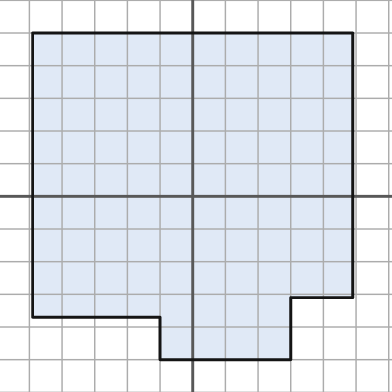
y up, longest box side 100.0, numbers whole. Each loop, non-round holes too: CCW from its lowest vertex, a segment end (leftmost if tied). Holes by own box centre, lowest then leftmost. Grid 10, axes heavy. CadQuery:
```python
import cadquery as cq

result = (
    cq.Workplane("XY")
    .moveTo(-10.0, -50.0)
    .lineTo(30.0, -50.0)
    .lineTo(30.0, -31.0)
    .lineTo(49.0, -31.0)
    .lineTo(49.0, 50.0)
    .lineTo(-49.0, 50.0)
    .lineTo(-49.0, -37.0)
    .lineTo(-10.0, -37.0)
    .close()
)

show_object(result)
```